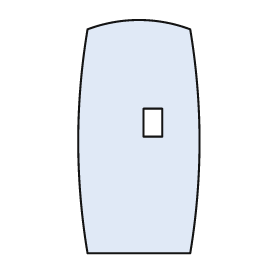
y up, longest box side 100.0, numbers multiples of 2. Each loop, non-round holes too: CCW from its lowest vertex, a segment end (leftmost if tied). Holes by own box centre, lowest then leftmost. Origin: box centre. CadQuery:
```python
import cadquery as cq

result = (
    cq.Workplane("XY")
    .moveTo(-22.0, -50.0)
    .lineTo(22.0, -50.0)
    .threePointArc((26.0, -2.0), (22.0, 46.0))
    .threePointArc((0.0, 50.0), (-22.0, 46.0))
    .threePointArc((-26.0, -2.0), (-22.0, -50.0))
    .close()
    .moveTo(2.0, 0.0)
    .lineTo(10.0, 0.0)
    .lineTo(10.0, 12.0)
    .lineTo(2.0, 12.0)
    .close()
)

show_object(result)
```